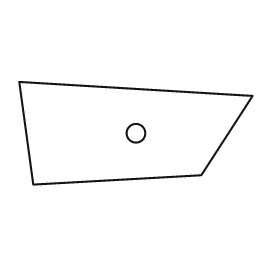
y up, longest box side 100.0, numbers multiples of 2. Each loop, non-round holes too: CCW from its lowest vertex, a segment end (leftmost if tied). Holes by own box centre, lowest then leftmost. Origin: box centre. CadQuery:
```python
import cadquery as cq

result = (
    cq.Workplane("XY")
    .moveTo(-44.0, -22.0)
    .lineTo(28.0, -18.0)
    .lineTo(50.0, 16.0)
    .lineTo(-50.0, 22.0)
    .close()
    .moveTo(0.0, 0.0)
    .circle(4.0)
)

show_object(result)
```